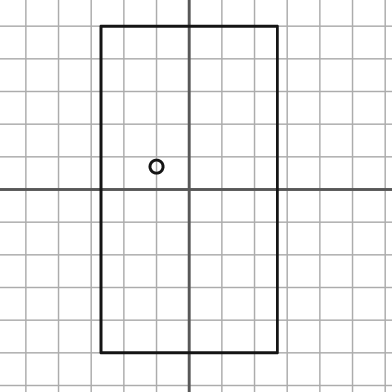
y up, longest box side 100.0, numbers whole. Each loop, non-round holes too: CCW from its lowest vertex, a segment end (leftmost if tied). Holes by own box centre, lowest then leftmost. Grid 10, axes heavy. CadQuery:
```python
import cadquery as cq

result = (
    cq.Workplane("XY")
    .moveTo(-27.0, -50.0)
    .lineTo(27.0, -50.0)
    .lineTo(27.0, 50.0)
    .lineTo(-27.0, 50.0)
    .close()
    .moveTo(-10.0, 7.0)
    .circle(2.0)
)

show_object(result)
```